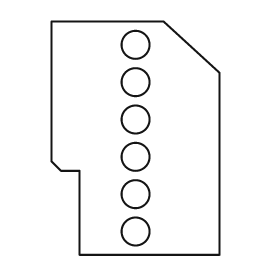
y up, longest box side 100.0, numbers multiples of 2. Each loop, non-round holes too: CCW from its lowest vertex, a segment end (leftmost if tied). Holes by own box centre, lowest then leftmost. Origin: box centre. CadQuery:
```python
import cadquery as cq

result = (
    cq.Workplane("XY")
    .moveTo(-24.0, -50.0)
    .lineTo(36.0, -50.0)
    .lineTo(36.0, 28.0)
    .lineTo(12.0, 50.0)
    .lineTo(-36.0, 50.0)
    .lineTo(-36.0, -10.0)
    .lineTo(-32.0, -14.0)
    .lineTo(-24.0, -14.0)
    .close()
    .moveTo(0.0, -40.0)
    .circle(6.0)
    .moveTo(0.0, -24.0)
    .circle(6.0)
    .moveTo(0.0, -8.0)
    .circle(6.0)
    .moveTo(0.0, 8.0)
    .circle(6.0)
    .moveTo(0.0, 24.0)
    .circle(6.0)
    .moveTo(0.0, 40.0)
    .circle(6.0)
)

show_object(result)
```